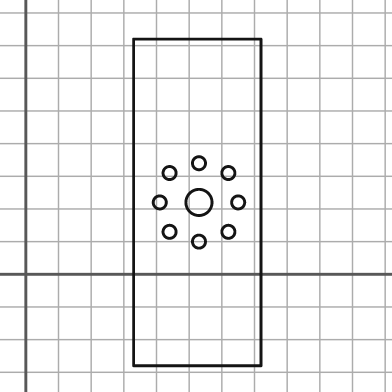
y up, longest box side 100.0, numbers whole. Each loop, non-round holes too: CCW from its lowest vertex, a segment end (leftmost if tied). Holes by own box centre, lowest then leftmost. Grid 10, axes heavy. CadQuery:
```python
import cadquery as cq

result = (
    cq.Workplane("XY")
    .moveTo(33.0, -28.0)
    .lineTo(72.0, -28.0)
    .lineTo(72.0, 72.0)
    .lineTo(33.0, 72.0)
    .close()
    .moveTo(53.0, 10.0)
    .circle(2.0)
    .moveTo(44.0, 13.0)
    .circle(2.0)
    .moveTo(62.0, 13.0)
    .circle(2.0)
    .moveTo(41.0, 22.0)
    .circle(2.0)
    .moveTo(53.0, 22.0)
    .circle(4.0)
    .moveTo(65.0, 22.0)
    .circle(2.0)
    .moveTo(44.0, 31.0)
    .circle(2.0)
    .moveTo(62.0, 31.0)
    .circle(2.0)
    .moveTo(53.0, 34.0)
    .circle(2.0)
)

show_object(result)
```